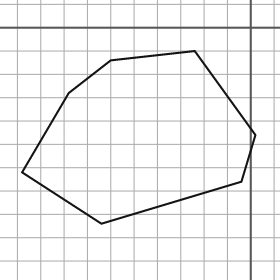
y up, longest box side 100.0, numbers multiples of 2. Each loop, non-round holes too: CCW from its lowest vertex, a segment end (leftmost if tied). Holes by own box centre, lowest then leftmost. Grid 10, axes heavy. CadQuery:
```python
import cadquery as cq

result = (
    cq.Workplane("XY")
    .moveTo(-64.0, -84.0)
    .lineTo(-4.0, -66.0)
    .lineTo(2.0, -46.0)
    .lineTo(-24.0, -10.0)
    .lineTo(-60.0, -14.0)
    .lineTo(-78.0, -28.0)
    .lineTo(-98.0, -62.0)
    .close()
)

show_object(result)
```